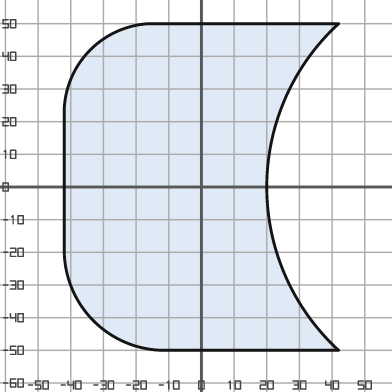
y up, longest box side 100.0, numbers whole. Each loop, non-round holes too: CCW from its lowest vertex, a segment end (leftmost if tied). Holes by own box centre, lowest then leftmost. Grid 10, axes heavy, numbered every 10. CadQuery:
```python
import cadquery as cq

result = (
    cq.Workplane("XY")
    .moveTo(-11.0, -50.0)
    .lineTo(42.0, -50.0)
    .threePointArc((20.0, 0.0), (42.0, 50.0))
    .lineTo(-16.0, 50.0)
    .threePointArc((-34.0, 42.0), (-42.0, 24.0))
    .lineTo(-42.0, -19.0)
    .threePointArc((-33.0, -41.0), (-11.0, -50.0))
    .close()
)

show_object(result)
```